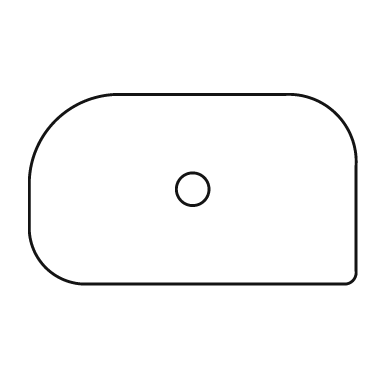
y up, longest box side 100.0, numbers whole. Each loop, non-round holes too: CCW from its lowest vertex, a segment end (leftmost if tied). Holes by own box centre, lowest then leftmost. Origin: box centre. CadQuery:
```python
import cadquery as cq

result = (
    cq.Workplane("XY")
    .moveTo(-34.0, -29.0)
    .lineTo(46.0, -29.0)
    .threePointArc((49.0, -28.0), (50.0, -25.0))
    .lineTo(50.0, 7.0)
    .threePointArc((44.0, 23.0), (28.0, 29.0))
    .lineTo(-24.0, 29.0)
    .threePointArc((-42.0, 21.0), (-50.0, 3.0))
    .lineTo(-50.0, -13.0)
    .threePointArc((-45.0, -24.0), (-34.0, -29.0))
    .close()
    .moveTo(0.0, 0.0)
    .circle(5.0)
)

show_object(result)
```